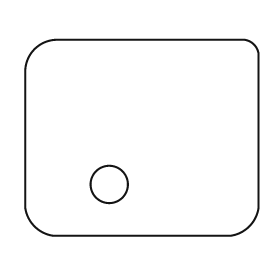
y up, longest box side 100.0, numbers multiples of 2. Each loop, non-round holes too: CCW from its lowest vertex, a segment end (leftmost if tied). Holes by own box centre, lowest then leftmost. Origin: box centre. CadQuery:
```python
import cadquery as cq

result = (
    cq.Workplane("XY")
    .moveTo(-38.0, -42.0)
    .lineTo(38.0, -42.0)
    .threePointArc((46.0, -38.0), (50.0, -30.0))
    .lineTo(50.0, 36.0)
    .threePointArc((48.0, 40.0), (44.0, 42.0))
    .lineTo(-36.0, 42.0)
    .threePointArc((-46.0, 38.0), (-50.0, 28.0))
    .lineTo(-50.0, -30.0)
    .threePointArc((-46.0, -38.0), (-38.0, -42.0))
    .close()
    .moveTo(-14.0, -20.0)
    .circle(8.0)
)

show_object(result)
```